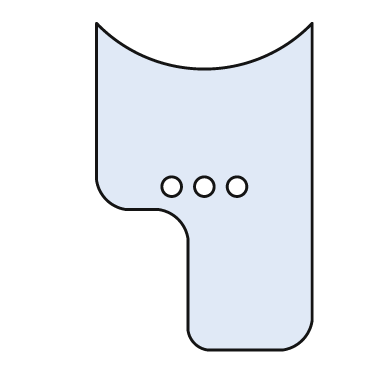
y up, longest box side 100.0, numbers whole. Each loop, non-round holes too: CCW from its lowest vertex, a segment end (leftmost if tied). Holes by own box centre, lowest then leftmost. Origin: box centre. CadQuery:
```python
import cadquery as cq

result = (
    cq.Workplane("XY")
    .moveTo(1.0, -50.0)
    .lineTo(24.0, -50.0)
    .threePointArc((30.0, -47.0), (33.0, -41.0))
    .lineTo(33.0, 50.0)
    .threePointArc((0.0, 36.0), (-33.0, 50.0))
    .lineTo(-33.0, 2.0)
    .threePointArc((-30.0, -4.0), (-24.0, -7.0))
    .lineTo(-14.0, -7.0)
    .threePointArc((-8.0, -10.0), (-5.0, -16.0))
    .lineTo(-5.0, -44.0)
    .threePointArc((-3.0, -48.0), (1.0, -50.0))
    .close()
    .moveTo(-10.0, 0.0)
    .circle(3.0)
    .moveTo(0.0, 0.0)
    .circle(3.0)
    .moveTo(10.0, 0.0)
    .circle(3.0)
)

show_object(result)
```